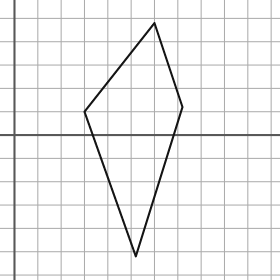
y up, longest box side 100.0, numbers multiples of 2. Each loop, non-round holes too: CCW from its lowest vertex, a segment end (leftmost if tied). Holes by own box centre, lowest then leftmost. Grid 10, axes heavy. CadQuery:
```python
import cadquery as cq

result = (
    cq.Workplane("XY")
    .moveTo(52.0, -52.0)
    .lineTo(72.0, 12.0)
    .lineTo(60.0, 48.0)
    .lineTo(30.0, 10.0)
    .close()
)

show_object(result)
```